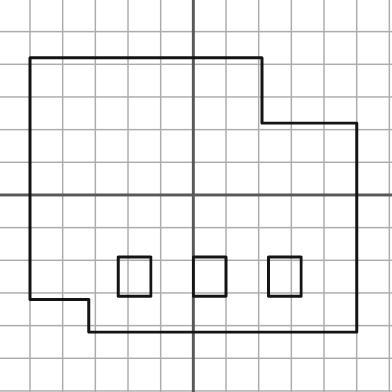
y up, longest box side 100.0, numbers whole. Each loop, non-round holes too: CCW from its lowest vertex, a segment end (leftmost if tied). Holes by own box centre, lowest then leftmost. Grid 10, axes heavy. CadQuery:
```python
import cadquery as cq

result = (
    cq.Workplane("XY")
    .moveTo(-32.0, -42.0)
    .lineTo(50.0, -42.0)
    .lineTo(50.0, 22.0)
    .lineTo(21.0, 22.0)
    .lineTo(21.0, 42.0)
    .lineTo(-50.0, 42.0)
    .lineTo(-50.0, -32.0)
    .lineTo(-32.0, -32.0)
    .close()
    .moveTo(-23.0, -31.0)
    .lineTo(-13.0, -31.0)
    .lineTo(-13.0, -19.0)
    .lineTo(-23.0, -19.0)
    .close()
    .moveTo(0.0, -31.0)
    .lineTo(10.0, -31.0)
    .lineTo(10.0, -19.0)
    .lineTo(0.0, -19.0)
    .close()
    .moveTo(23.0, -31.0)
    .lineTo(33.0, -31.0)
    .lineTo(33.0, -19.0)
    .lineTo(23.0, -19.0)
    .close()
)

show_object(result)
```